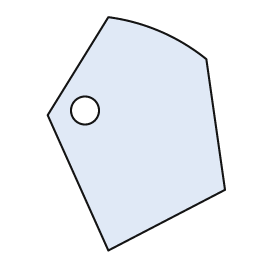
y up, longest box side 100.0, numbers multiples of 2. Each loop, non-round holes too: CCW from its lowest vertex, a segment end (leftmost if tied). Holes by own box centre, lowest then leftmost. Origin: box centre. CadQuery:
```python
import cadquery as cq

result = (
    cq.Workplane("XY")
    .moveTo(-12.0, -50.0)
    .lineTo(38.0, -24.0)
    .lineTo(30.0, 32.0)
    .threePointArc((10.0, 44.0), (-12.0, 50.0))
    .lineTo(-38.0, 8.0)
    .close()
    .moveTo(-22.0, 10.0)
    .circle(6.0)
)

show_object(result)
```